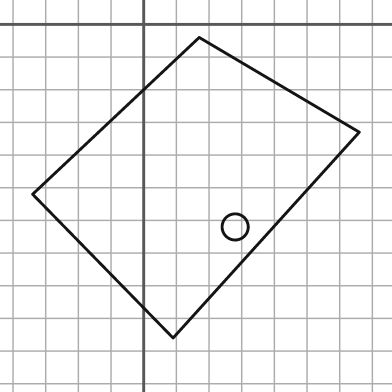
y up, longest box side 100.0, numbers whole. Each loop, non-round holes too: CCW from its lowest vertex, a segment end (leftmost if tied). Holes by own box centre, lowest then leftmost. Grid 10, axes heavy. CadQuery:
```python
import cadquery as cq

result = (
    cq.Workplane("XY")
    .moveTo(9.0, -96.0)
    .lineTo(66.0, -33.0)
    .lineTo(17.0, -4.0)
    .lineTo(-34.0, -52.0)
    .close()
    .moveTo(28.0, -62.0)
    .circle(4.0)
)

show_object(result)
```